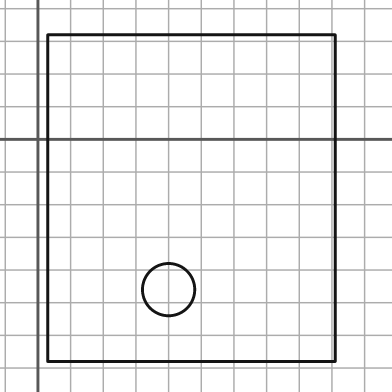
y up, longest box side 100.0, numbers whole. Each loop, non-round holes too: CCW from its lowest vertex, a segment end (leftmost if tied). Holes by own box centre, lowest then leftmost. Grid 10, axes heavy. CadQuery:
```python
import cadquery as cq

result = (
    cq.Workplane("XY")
    .moveTo(3.0, -68.0)
    .lineTo(91.0, -68.0)
    .lineTo(91.0, 32.0)
    .lineTo(3.0, 32.0)
    .close()
    .moveTo(40.0, -46.0)
    .circle(8.0)
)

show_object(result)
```